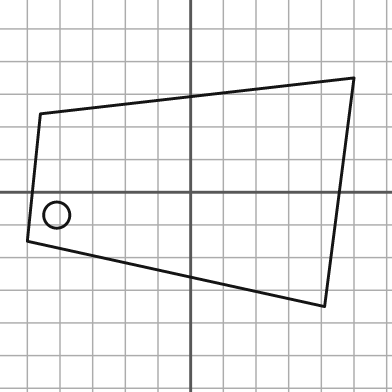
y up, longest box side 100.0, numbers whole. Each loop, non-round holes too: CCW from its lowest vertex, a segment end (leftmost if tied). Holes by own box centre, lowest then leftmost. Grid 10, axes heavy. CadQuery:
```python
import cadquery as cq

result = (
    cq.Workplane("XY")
    .moveTo(41.0, -35.0)
    .lineTo(50.0, 35.0)
    .lineTo(-46.0, 24.0)
    .lineTo(-50.0, -15.0)
    .close()
    .moveTo(-41.0, -7.0)
    .circle(4.0)
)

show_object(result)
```